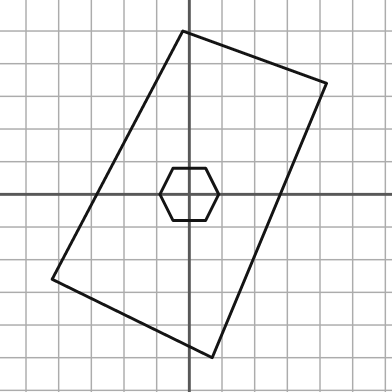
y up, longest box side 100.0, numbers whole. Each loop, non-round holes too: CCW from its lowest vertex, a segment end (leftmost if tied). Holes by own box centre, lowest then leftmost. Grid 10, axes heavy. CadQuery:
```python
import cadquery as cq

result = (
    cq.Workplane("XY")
    .moveTo(7.0, -50.0)
    .lineTo(42.0, 34.0)
    .lineTo(-2.0, 50.0)
    .lineTo(-42.0, -26.0)
    .close()
    .moveTo(-5.0, -8.0)
    .lineTo(5.0, -8.0)
    .lineTo(9.0, 0.0)
    .lineTo(5.0, 8.0)
    .lineTo(-5.0, 8.0)
    .lineTo(-9.0, 0.0)
    .close()
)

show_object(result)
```